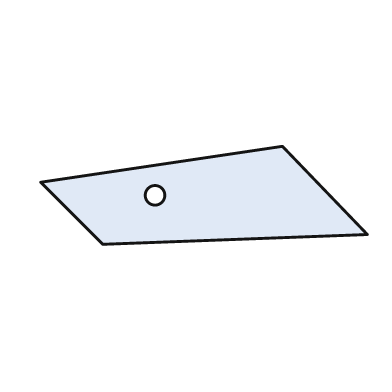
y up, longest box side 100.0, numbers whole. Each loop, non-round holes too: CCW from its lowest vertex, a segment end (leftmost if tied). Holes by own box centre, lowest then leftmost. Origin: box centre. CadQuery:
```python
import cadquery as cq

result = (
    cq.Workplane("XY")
    .moveTo(-31.0, -15.0)
    .lineTo(50.0, -12.0)
    .lineTo(24.0, 15.0)
    .lineTo(-50.0, 4.0)
    .close()
    .moveTo(-15.0, 0.0)
    .circle(3.0)
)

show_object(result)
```